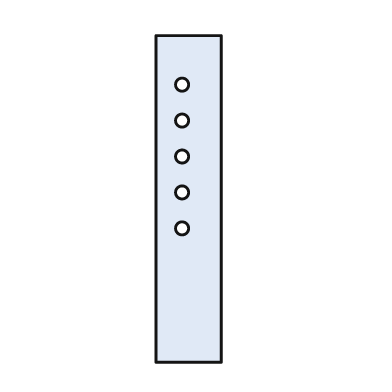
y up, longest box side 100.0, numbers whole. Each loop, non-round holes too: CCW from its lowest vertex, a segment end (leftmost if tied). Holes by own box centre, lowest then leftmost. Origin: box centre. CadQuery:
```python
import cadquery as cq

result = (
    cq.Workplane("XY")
    .moveTo(-10.0, -50.0)
    .lineTo(10.0, -50.0)
    .lineTo(10.0, 50.0)
    .lineTo(-10.0, 50.0)
    .close()
    .moveTo(-2.0, -9.0)
    .circle(2.0)
    .moveTo(-2.0, 2.0)
    .circle(2.0)
    .moveTo(-2.0, 13.0)
    .circle(2.0)
    .moveTo(-2.0, 24.0)
    .circle(2.0)
    .moveTo(-2.0, 35.0)
    .circle(2.0)
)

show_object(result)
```